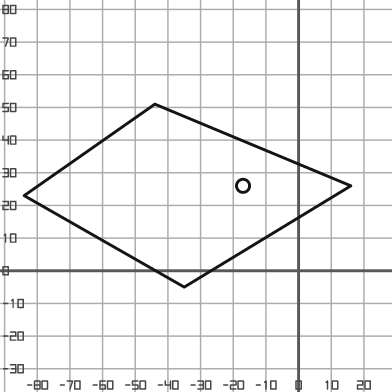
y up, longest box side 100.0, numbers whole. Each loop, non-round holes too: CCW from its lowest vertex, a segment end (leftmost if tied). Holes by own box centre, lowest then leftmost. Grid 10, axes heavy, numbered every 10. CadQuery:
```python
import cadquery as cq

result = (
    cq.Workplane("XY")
    .moveTo(-35.0, -5.0)
    .lineTo(16.0, 26.0)
    .lineTo(-44.0, 51.0)
    .lineTo(-84.0, 23.0)
    .close()
    .moveTo(-17.0, 26.0)
    .circle(2.0)
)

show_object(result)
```